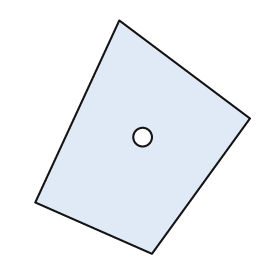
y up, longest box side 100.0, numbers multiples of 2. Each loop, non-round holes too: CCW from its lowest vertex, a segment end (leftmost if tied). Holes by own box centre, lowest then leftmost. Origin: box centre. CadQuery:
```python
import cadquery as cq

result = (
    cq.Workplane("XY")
    .moveTo(4.0, -50.0)
    .lineTo(46.0, 8.0)
    .lineTo(-10.0, 50.0)
    .lineTo(-46.0, -28.0)
    .close()
    .moveTo(0.0, 0.0)
    .circle(4.0)
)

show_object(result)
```